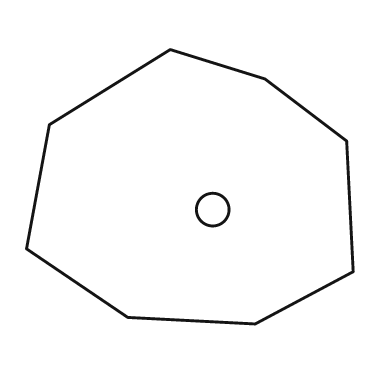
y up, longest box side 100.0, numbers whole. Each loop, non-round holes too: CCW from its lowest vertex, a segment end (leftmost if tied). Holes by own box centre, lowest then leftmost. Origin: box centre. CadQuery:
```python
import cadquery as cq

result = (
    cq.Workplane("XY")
    .moveTo(20.0, -42.0)
    .lineTo(50.0, -26.0)
    .lineTo(48.0, 14.0)
    .lineTo(23.0, 33.0)
    .lineTo(-6.0, 42.0)
    .lineTo(-43.0, 19.0)
    .lineTo(-50.0, -19.0)
    .lineTo(-19.0, -40.0)
    .close()
    .moveTo(7.0, -7.0)
    .circle(5.0)
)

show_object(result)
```